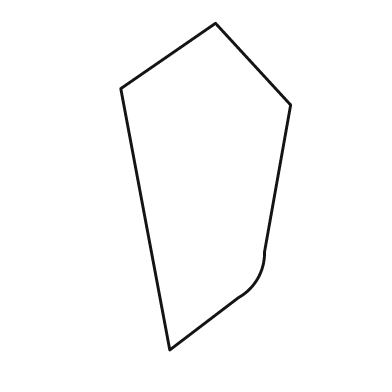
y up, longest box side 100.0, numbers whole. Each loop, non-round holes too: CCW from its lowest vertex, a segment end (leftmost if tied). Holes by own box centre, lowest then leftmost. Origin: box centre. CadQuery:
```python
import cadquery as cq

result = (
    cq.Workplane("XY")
    .moveTo(-11.0, -50.0)
    .lineTo(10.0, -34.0)
    .threePointArc((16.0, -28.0), (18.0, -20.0))
    .lineTo(26.0, 25.0)
    .lineTo(3.0, 50.0)
    .lineTo(-26.0, 30.0)
    .close()
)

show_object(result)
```